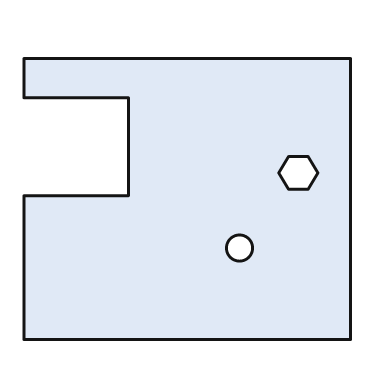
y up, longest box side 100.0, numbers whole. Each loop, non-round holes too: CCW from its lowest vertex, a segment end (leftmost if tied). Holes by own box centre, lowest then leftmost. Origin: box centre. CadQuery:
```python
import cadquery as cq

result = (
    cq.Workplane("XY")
    .moveTo(-50.0, -43.0)
    .lineTo(50.0, -43.0)
    .lineTo(50.0, 43.0)
    .lineTo(-50.0, 43.0)
    .lineTo(-50.0, 31.0)
    .lineTo(-18.0, 31.0)
    .lineTo(-18.0, 1.0)
    .lineTo(-50.0, 1.0)
    .close()
    .moveTo(16.0, -15.0)
    .circle(4.0)
    .moveTo(31.0, 3.0)
    .lineTo(37.0, 3.0)
    .lineTo(40.0, 8.0)
    .lineTo(37.0, 13.0)
    .lineTo(31.0, 13.0)
    .lineTo(28.0, 8.0)
    .close()
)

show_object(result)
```